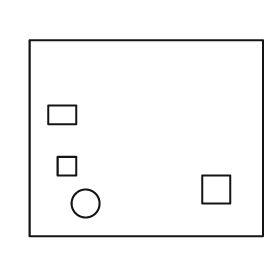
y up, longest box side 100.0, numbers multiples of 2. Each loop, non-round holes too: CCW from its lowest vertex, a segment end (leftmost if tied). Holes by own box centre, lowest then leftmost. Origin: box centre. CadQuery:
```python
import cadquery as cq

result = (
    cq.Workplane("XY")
    .moveTo(-50.0, -42.0)
    .lineTo(50.0, -42.0)
    .lineTo(50.0, 42.0)
    .lineTo(-50.0, 42.0)
    .close()
    .moveTo(-26.0, -28.0)
    .circle(6.0)
    .moveTo(24.0, -28.0)
    .lineTo(36.0, -28.0)
    .lineTo(36.0, -16.0)
    .lineTo(24.0, -16.0)
    .close()
    .moveTo(-38.0, -16.0)
    .lineTo(-30.0, -16.0)
    .lineTo(-30.0, -8.0)
    .lineTo(-38.0, -8.0)
    .close()
    .moveTo(-42.0, 6.0)
    .lineTo(-30.0, 6.0)
    .lineTo(-30.0, 14.0)
    .lineTo(-42.0, 14.0)
    .close()
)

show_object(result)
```